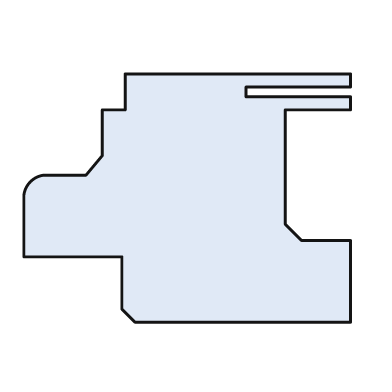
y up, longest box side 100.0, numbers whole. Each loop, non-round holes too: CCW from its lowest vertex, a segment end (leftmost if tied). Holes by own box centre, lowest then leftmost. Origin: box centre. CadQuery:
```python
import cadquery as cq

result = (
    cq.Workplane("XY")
    .moveTo(-16.0, -38.0)
    .lineTo(50.0, -38.0)
    .lineTo(50.0, -13.0)
    .lineTo(35.0, -13.0)
    .lineTo(30.0, -8.0)
    .lineTo(30.0, 27.0)
    .lineTo(50.0, 27.0)
    .lineTo(50.0, 31.0)
    .lineTo(18.0, 31.0)
    .lineTo(18.0, 34.0)
    .lineTo(50.0, 34.0)
    .lineTo(50.0, 38.0)
    .lineTo(-19.0, 38.0)
    .lineTo(-19.0, 27.0)
    .lineTo(-26.0, 27.0)
    .lineTo(-26.0, 13.0)
    .lineTo(-31.0, 7.0)
    .lineTo(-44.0, 7.0)
    .threePointArc((-48.0, 5.0), (-50.0, 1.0))
    .lineTo(-50.0, -18.0)
    .lineTo(-20.0, -18.0)
    .lineTo(-20.0, -34.0)
    .close()
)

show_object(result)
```